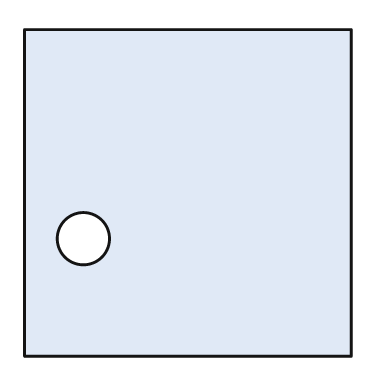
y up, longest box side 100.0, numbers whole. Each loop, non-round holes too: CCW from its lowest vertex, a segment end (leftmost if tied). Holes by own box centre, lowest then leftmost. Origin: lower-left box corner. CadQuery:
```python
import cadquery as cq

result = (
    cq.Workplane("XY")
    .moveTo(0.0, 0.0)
    .lineTo(100.0, 0.0)
    .lineTo(100.0, 100.0)
    .lineTo(0.0, 100.0)
    .close()
    .moveTo(18.0, 36.0)
    .circle(8.0)
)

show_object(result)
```